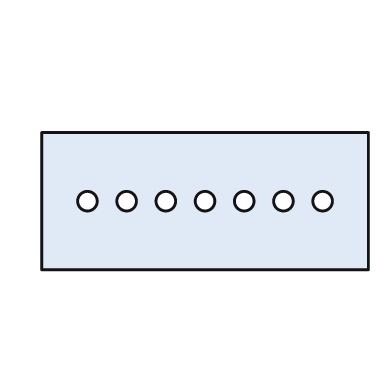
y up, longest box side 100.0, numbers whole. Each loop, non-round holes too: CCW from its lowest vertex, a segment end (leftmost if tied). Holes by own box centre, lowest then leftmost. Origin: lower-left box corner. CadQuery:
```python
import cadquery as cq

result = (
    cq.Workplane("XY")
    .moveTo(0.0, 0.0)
    .lineTo(100.0, 0.0)
    .lineTo(100.0, 42.0)
    .lineTo(0.0, 42.0)
    .close()
    .moveTo(14.0, 21.0)
    .circle(3.0)
    .moveTo(26.0, 21.0)
    .circle(3.0)
    .moveTo(38.0, 21.0)
    .circle(3.0)
    .moveTo(50.0, 21.0)
    .circle(3.0)
    .moveTo(62.0, 21.0)
    .circle(3.0)
    .moveTo(74.0, 21.0)
    .circle(3.0)
    .moveTo(86.0, 21.0)
    .circle(3.0)
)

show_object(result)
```